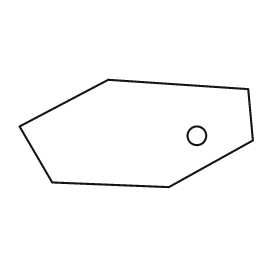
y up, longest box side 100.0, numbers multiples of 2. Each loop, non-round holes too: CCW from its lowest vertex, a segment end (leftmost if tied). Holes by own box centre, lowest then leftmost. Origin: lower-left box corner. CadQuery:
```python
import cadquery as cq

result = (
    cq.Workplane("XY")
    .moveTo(64.0, 0.0)
    .lineTo(100.0, 20.0)
    .lineTo(98.0, 42.0)
    .lineTo(38.0, 46.0)
    .lineTo(0.0, 26.0)
    .lineTo(14.0, 2.0)
    .close()
    .moveTo(76.0, 22.0)
    .circle(4.0)
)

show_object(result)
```